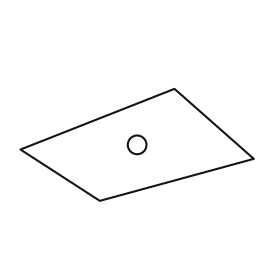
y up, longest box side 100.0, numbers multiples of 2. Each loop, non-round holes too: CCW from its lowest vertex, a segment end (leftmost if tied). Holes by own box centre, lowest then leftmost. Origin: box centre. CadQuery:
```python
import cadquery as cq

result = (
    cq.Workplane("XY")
    .moveTo(-16.0, -24.0)
    .lineTo(50.0, -6.0)
    .lineTo(16.0, 24.0)
    .lineTo(-50.0, -2.0)
    .close()
    .moveTo(0.0, 0.0)
    .circle(4.0)
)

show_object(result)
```